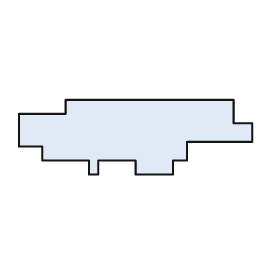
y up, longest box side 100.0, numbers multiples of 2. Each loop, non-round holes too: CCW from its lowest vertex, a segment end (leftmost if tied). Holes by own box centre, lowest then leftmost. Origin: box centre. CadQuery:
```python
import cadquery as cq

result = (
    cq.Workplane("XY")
    .moveTo(-20.0, -16.0)
    .lineTo(-16.0, -16.0)
    .lineTo(-16.0, -10.0)
    .lineTo(0.0, -10.0)
    .lineTo(0.0, -16.0)
    .lineTo(16.0, -16.0)
    .lineTo(16.0, -10.0)
    .lineTo(22.0, -10.0)
    .lineTo(22.0, -2.0)
    .lineTo(50.0, -2.0)
    .lineTo(50.0, 6.0)
    .lineTo(42.0, 6.0)
    .lineTo(42.0, 16.0)
    .lineTo(-30.0, 16.0)
    .lineTo(-30.0, 10.0)
    .lineTo(-50.0, 10.0)
    .lineTo(-50.0, -4.0)
    .lineTo(-40.0, -4.0)
    .lineTo(-40.0, -10.0)
    .lineTo(-20.0, -10.0)
    .close()
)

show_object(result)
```